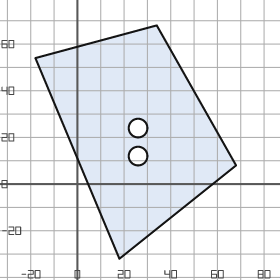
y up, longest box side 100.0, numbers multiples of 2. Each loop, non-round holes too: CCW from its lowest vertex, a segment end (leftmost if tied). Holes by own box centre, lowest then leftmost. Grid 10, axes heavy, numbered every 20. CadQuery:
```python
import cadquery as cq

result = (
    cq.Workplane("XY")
    .moveTo(18.0, -32.0)
    .lineTo(68.0, 8.0)
    .lineTo(34.0, 68.0)
    .lineTo(-18.0, 54.0)
    .close()
    .moveTo(26.0, 12.0)
    .circle(4.0)
    .moveTo(26.0, 24.0)
    .circle(4.0)
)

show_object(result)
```